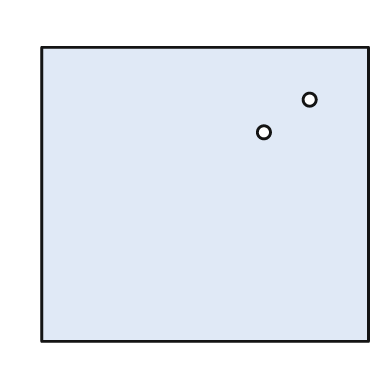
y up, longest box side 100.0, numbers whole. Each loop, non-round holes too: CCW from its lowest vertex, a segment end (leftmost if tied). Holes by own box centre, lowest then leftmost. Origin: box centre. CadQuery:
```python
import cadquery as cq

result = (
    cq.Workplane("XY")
    .moveTo(-50.0, -45.0)
    .lineTo(50.0, -45.0)
    .lineTo(50.0, 45.0)
    .lineTo(-50.0, 45.0)
    .close()
    .moveTo(18.0, 19.0)
    .circle(2.0)
    .moveTo(32.0, 29.0)
    .circle(2.0)
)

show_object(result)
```